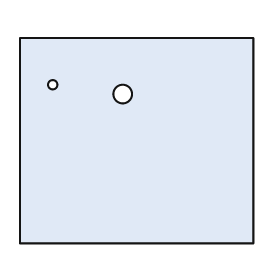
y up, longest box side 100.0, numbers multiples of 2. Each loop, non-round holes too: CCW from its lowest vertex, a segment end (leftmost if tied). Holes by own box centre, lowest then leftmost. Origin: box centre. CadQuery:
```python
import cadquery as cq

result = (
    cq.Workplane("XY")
    .moveTo(-50.0, -44.0)
    .lineTo(50.0, -44.0)
    .lineTo(50.0, 44.0)
    .lineTo(-50.0, 44.0)
    .close()
    .moveTo(-6.0, 20.0)
    .circle(4.0)
    .moveTo(-36.0, 24.0)
    .circle(2.0)
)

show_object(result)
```